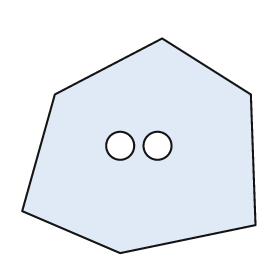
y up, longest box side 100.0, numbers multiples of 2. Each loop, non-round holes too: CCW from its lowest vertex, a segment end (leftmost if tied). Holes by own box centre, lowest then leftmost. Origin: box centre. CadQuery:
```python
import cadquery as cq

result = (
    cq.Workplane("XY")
    .moveTo(-8.0, -46.0)
    .lineTo(50.0, -34.0)
    .lineTo(48.0, 22.0)
    .lineTo(10.0, 46.0)
    .lineTo(-36.0, 22.0)
    .lineTo(-50.0, -28.0)
    .close()
    .moveTo(-8.0, 0.0)
    .circle(6.0)
    .moveTo(8.0, 0.0)
    .circle(6.0)
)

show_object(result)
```